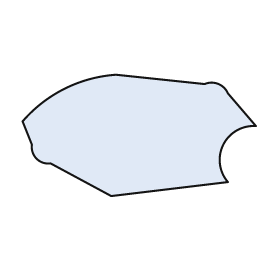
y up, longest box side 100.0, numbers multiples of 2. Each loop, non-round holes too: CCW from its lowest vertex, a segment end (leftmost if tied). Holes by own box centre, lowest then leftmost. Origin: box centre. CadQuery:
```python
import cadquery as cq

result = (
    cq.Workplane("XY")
    .moveTo(-12.0, -26.0)
    .lineTo(38.0, -20.0)
    .threePointArc((36.0, -4.0), (50.0, 4.0))
    .lineTo(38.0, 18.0)
    .threePointArc((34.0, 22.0), (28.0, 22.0))
    .lineTo(-10.0, 26.0)
    .threePointArc((-32.0, 20.0), (-50.0, 6.0))
    .lineTo(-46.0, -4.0)
    .threePointArc((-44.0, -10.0), (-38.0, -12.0))
    .close()
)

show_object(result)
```